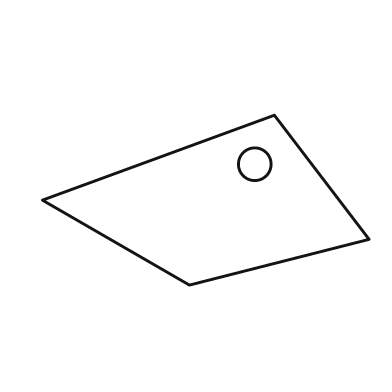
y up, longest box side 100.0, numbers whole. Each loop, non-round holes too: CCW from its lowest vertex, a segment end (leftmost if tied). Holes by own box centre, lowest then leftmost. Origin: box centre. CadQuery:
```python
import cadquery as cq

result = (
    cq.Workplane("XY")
    .moveTo(-5.0, -26.0)
    .lineTo(50.0, -12.0)
    .lineTo(21.0, 26.0)
    .lineTo(-50.0, 0.0)
    .close()
    .moveTo(15.0, 11.0)
    .circle(5.0)
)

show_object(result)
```